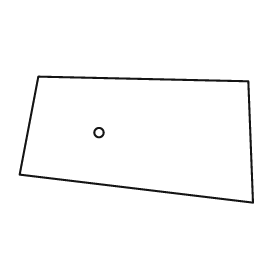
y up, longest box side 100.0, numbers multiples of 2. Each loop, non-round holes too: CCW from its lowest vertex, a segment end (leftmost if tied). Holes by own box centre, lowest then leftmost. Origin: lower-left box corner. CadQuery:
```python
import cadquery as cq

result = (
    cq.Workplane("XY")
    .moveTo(100.0, 0.0)
    .lineTo(98.0, 52.0)
    .lineTo(8.0, 54.0)
    .lineTo(0.0, 12.0)
    .close()
    .moveTo(34.0, 30.0)
    .circle(2.0)
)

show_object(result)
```